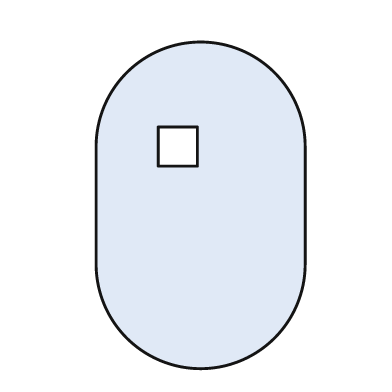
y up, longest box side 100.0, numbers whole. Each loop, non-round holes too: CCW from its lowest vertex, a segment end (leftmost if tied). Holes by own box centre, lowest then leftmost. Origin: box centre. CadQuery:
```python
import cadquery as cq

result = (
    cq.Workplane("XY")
    .moveTo(-32.0, -18.0)
    .threePointArc((0.0, -50.0), (32.0, -18.0))
    .lineTo(32.0, 18.0)
    .threePointArc((0.0, 50.0), (-32.0, 18.0))
    .close()
    .moveTo(-13.0, 12.0)
    .lineTo(-1.0, 12.0)
    .lineTo(-1.0, 24.0)
    .lineTo(-13.0, 24.0)
    .close()
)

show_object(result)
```